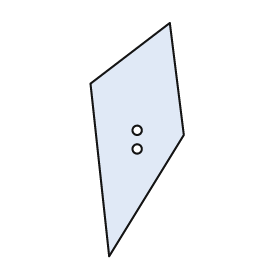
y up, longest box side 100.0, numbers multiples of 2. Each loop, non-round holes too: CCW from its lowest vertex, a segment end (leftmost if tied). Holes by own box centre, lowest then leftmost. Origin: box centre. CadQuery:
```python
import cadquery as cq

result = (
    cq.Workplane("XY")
    .moveTo(-12.0, -50.0)
    .lineTo(20.0, 2.0)
    .lineTo(14.0, 50.0)
    .lineTo(-20.0, 24.0)
    .close()
    .moveTo(0.0, -4.0)
    .circle(2.0)
    .moveTo(0.0, 4.0)
    .circle(2.0)
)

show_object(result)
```